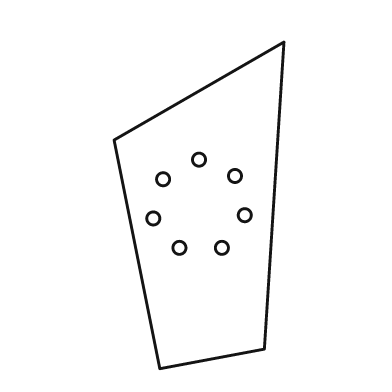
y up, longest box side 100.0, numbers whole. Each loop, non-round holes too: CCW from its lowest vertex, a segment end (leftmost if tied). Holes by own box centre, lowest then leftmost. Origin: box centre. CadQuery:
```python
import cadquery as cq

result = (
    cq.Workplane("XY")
    .moveTo(-12.0, -50.0)
    .lineTo(20.0, -44.0)
    .lineTo(26.0, 50.0)
    .lineTo(-26.0, 20.0)
    .close()
    .moveTo(-6.0, -13.0)
    .circle(2.0)
    .moveTo(7.0, -13.0)
    .circle(2.0)
    .moveTo(-14.0, -4.0)
    .circle(2.0)
    .moveTo(14.0, -3.0)
    .circle(2.0)
    .moveTo(-11.0, 8.0)
    .circle(2.0)
    .moveTo(11.0, 9.0)
    .circle(2.0)
    .moveTo(0.0, 14.0)
    .circle(2.0)
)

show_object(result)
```